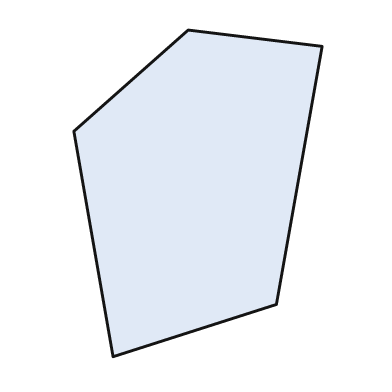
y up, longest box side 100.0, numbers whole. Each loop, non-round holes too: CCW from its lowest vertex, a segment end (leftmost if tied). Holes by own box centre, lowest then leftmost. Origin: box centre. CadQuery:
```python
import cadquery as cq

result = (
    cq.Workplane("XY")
    .moveTo(-26.0, -50.0)
    .lineTo(24.0, -34.0)
    .lineTo(38.0, 45.0)
    .lineTo(-3.0, 50.0)
    .lineTo(-38.0, 19.0)
    .close()
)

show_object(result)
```